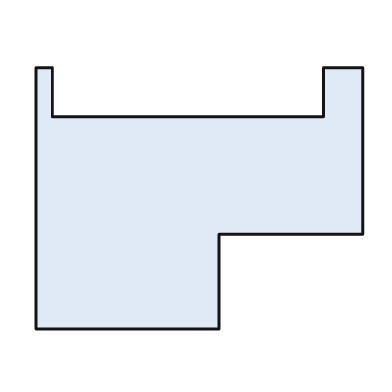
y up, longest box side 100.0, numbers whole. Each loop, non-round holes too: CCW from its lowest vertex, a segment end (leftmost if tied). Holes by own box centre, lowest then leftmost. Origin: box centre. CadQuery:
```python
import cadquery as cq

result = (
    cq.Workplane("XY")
    .moveTo(-50.0, -40.0)
    .lineTo(6.0, -40.0)
    .lineTo(6.0, -11.0)
    .lineTo(50.0, -11.0)
    .lineTo(50.0, 40.0)
    .lineTo(38.0, 40.0)
    .lineTo(38.0, 25.0)
    .lineTo(-45.0, 25.0)
    .lineTo(-45.0, 40.0)
    .lineTo(-50.0, 40.0)
    .close()
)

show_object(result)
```